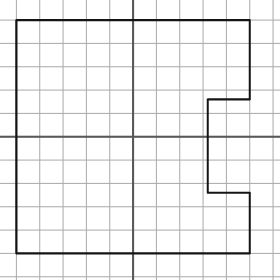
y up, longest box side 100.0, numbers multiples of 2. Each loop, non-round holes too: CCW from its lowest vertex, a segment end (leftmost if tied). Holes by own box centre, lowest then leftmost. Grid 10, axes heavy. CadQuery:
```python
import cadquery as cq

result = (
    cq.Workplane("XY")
    .moveTo(-50.0, -50.0)
    .lineTo(50.0, -50.0)
    .lineTo(50.0, -24.0)
    .lineTo(32.0, -24.0)
    .lineTo(32.0, 16.0)
    .lineTo(50.0, 16.0)
    .lineTo(50.0, 50.0)
    .lineTo(-50.0, 50.0)
    .close()
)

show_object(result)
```